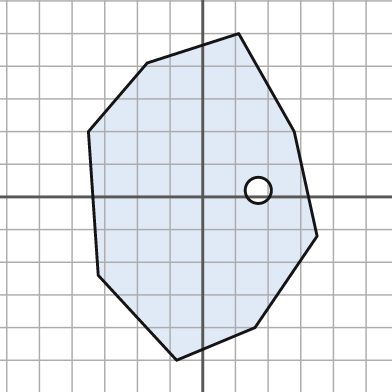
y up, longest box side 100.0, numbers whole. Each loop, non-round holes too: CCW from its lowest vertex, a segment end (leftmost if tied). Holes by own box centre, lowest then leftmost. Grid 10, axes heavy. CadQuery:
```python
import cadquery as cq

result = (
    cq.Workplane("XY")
    .moveTo(-8.0, -50.0)
    .lineTo(16.0, -40.0)
    .lineTo(35.0, -12.0)
    .lineTo(28.0, 20.0)
    .lineTo(11.0, 50.0)
    .lineTo(-17.0, 41.0)
    .lineTo(-35.0, 20.0)
    .lineTo(-32.0, -24.0)
    .close()
    .moveTo(17.0, 2.0)
    .circle(4.0)
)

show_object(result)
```